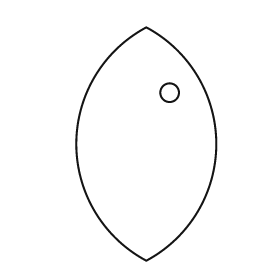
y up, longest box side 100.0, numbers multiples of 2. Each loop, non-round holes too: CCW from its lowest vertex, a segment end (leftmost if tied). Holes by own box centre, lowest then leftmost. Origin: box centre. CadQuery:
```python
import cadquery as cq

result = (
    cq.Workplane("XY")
    .moveTo(0.0, -50.0)
    .threePointArc((30.0, 0.0), (0.0, 50.0))
    .threePointArc((-30.0, 0.0), (0.0, -50.0))
    .close()
    .moveTo(10.0, 22.0)
    .circle(4.0)
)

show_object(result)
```